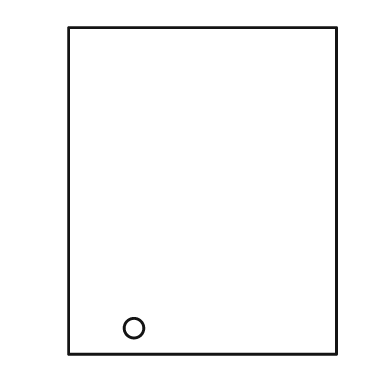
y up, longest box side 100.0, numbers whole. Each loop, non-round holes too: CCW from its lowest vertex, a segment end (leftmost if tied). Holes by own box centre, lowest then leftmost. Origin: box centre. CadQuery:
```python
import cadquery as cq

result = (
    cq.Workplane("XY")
    .moveTo(-41.0, -50.0)
    .lineTo(41.0, -50.0)
    .lineTo(41.0, 50.0)
    .lineTo(-41.0, 50.0)
    .close()
    .moveTo(-21.0, -42.0)
    .circle(3.0)
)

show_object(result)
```